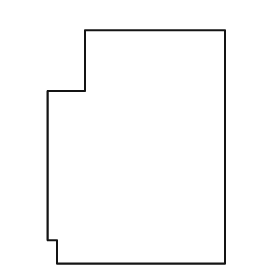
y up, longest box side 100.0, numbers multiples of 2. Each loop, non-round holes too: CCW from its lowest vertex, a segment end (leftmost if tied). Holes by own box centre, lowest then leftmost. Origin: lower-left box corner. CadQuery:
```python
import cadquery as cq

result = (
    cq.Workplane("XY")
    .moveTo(4.0, 0.0)
    .lineTo(76.0, 0.0)
    .lineTo(76.0, 100.0)
    .lineTo(16.0, 100.0)
    .lineTo(16.0, 74.0)
    .lineTo(0.0, 74.0)
    .lineTo(0.0, 10.0)
    .lineTo(4.0, 10.0)
    .close()
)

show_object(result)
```